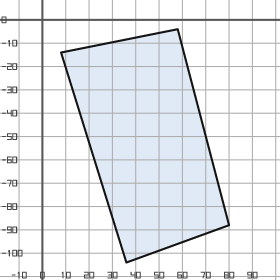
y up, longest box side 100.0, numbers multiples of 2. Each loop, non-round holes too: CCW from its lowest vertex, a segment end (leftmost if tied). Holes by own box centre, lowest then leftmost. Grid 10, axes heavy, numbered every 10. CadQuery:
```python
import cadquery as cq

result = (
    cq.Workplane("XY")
    .moveTo(36.0, -104.0)
    .lineTo(80.0, -88.0)
    .lineTo(58.0, -4.0)
    .lineTo(8.0, -14.0)
    .close()
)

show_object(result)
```